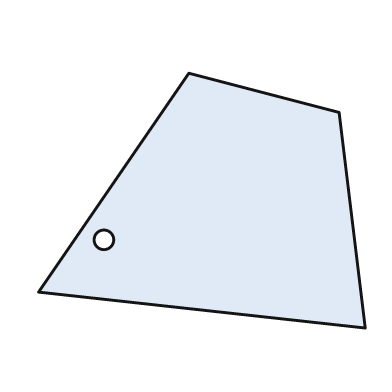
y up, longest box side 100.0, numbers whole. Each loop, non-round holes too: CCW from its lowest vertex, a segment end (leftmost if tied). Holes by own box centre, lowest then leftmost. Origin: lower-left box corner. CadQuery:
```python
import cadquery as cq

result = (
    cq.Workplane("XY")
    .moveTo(100.0, 0.0)
    .lineTo(92.0, 66.0)
    .lineTo(46.0, 78.0)
    .lineTo(0.0, 11.0)
    .close()
    .moveTo(20.0, 27.0)
    .circle(3.0)
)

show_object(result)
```